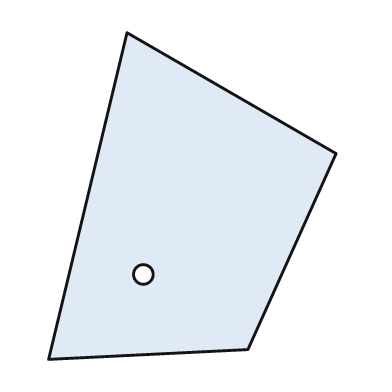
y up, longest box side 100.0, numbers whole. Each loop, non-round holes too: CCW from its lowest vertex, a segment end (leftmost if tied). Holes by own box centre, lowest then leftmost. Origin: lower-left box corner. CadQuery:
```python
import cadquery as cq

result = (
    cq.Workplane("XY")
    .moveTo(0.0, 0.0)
    .lineTo(61.0, 3.0)
    .lineTo(88.0, 63.0)
    .lineTo(24.0, 100.0)
    .close()
    .moveTo(29.0, 26.0)
    .circle(3.0)
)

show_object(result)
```